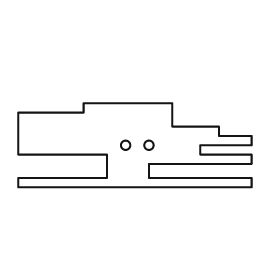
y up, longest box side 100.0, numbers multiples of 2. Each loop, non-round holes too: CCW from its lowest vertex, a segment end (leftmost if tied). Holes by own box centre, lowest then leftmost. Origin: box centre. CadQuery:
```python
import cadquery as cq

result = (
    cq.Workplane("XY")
    .moveTo(-50.0, -18.0)
    .lineTo(50.0, -18.0)
    .lineTo(50.0, -14.0)
    .lineTo(6.0, -14.0)
    .lineTo(6.0, -8.0)
    .lineTo(50.0, -8.0)
    .lineTo(50.0, -4.0)
    .lineTo(28.0, -4.0)
    .lineTo(28.0, 0.0)
    .lineTo(50.0, 0.0)
    .lineTo(50.0, 4.0)
    .lineTo(36.0, 4.0)
    .lineTo(36.0, 8.0)
    .lineTo(16.0, 8.0)
    .lineTo(16.0, 18.0)
    .lineTo(-22.0, 18.0)
    .lineTo(-22.0, 14.0)
    .lineTo(-50.0, 14.0)
    .lineTo(-50.0, -4.0)
    .lineTo(-12.0, -4.0)
    .lineTo(-12.0, -14.0)
    .lineTo(-50.0, -14.0)
    .close()
    .moveTo(-4.0, 0.0)
    .circle(2.0)
    .moveTo(6.0, 0.0)
    .circle(2.0)
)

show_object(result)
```